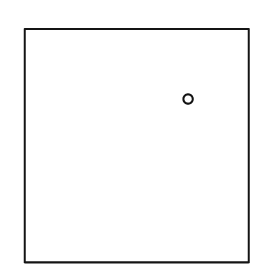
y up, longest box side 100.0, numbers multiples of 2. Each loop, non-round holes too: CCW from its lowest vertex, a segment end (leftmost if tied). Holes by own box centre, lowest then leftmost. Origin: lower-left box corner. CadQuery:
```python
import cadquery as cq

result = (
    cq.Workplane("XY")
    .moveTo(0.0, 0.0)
    .lineTo(96.0, 0.0)
    .lineTo(96.0, 100.0)
    .lineTo(0.0, 100.0)
    .close()
    .moveTo(70.0, 70.0)
    .circle(2.0)
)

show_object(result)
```